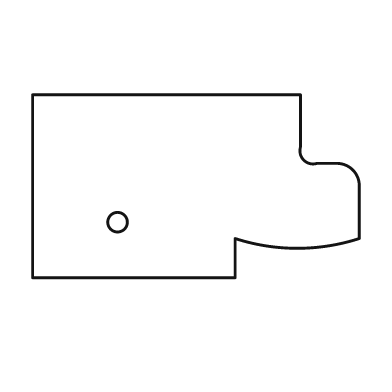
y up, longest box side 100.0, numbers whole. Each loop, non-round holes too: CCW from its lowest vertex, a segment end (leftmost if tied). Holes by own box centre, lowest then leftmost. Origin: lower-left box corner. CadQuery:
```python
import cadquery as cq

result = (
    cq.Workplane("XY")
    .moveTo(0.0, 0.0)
    .lineTo(62.0, 0.0)
    .lineTo(62.0, 12.0)
    .threePointArc((81.0, 9.0), (100.0, 12.0))
    .lineTo(100.0, 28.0)
    .threePointArc((98.0, 33.0), (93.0, 35.0))
    .lineTo(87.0, 35.0)
    .threePointArc((83.0, 36.0), (82.0, 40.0))
    .lineTo(82.0, 56.0)
    .lineTo(0.0, 56.0)
    .close()
    .moveTo(26.0, 17.0)
    .circle(3.0)
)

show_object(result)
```